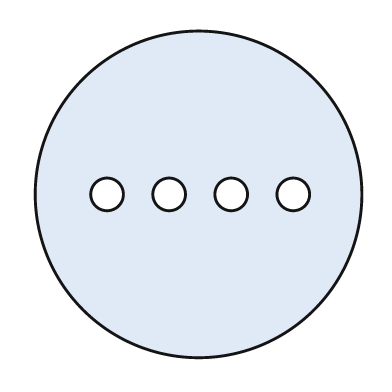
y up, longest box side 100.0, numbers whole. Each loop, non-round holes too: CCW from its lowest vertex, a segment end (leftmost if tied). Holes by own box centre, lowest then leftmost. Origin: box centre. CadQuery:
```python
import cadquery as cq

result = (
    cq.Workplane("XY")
    .moveTo(0.0, 0.0)
    .circle(50.0)
    .moveTo(-28.0, 0.0)
    .circle(5.0)
    .moveTo(-9.0, 0.0)
    .circle(5.0)
    .moveTo(10.0, 0.0)
    .circle(5.0)
    .moveTo(29.0, 0.0)
    .circle(5.0)
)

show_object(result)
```